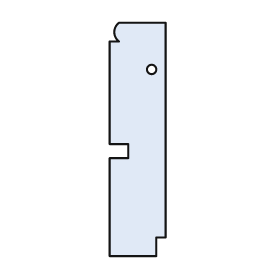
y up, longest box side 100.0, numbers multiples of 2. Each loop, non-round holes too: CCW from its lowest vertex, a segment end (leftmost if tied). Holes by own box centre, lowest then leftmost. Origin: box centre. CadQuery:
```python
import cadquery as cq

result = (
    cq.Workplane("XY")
    .moveTo(-12.0, -50.0)
    .lineTo(8.0, -50.0)
    .lineTo(8.0, -42.0)
    .lineTo(12.0, -42.0)
    .lineTo(12.0, 50.0)
    .lineTo(-8.0, 50.0)
    .threePointArc((-10.0, 46.0), (-8.0, 42.0))
    .lineTo(-12.0, 42.0)
    .lineTo(-12.0, -2.0)
    .lineTo(-4.0, -2.0)
    .lineTo(-4.0, -8.0)
    .lineTo(-12.0, -8.0)
    .close()
    .moveTo(6.0, 30.0)
    .circle(2.0)
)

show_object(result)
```